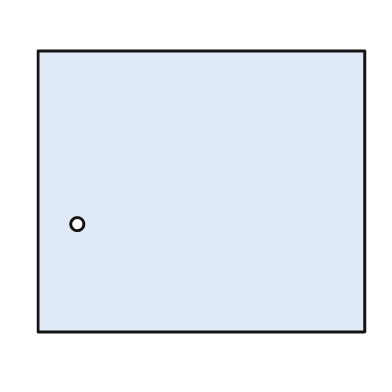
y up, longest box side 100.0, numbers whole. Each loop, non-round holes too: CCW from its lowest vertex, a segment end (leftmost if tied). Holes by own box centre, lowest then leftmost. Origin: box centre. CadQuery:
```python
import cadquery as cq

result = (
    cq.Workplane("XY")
    .moveTo(-50.0, -43.0)
    .lineTo(50.0, -43.0)
    .lineTo(50.0, 43.0)
    .lineTo(-50.0, 43.0)
    .close()
    .moveTo(-38.0, -10.0)
    .circle(2.0)
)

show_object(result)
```